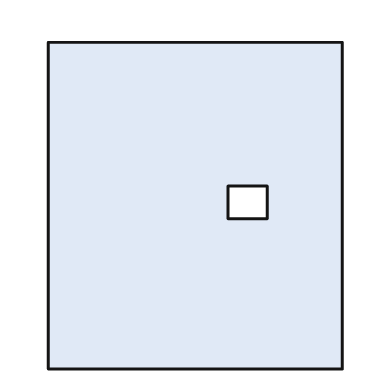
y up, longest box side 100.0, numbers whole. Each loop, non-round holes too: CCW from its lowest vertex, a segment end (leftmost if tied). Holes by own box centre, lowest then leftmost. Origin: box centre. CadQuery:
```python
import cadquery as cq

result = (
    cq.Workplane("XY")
    .moveTo(-45.0, -50.0)
    .lineTo(45.0, -50.0)
    .lineTo(45.0, 50.0)
    .lineTo(-45.0, 50.0)
    .close()
    .moveTo(10.0, -4.0)
    .lineTo(22.0, -4.0)
    .lineTo(22.0, 6.0)
    .lineTo(10.0, 6.0)
    .close()
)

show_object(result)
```